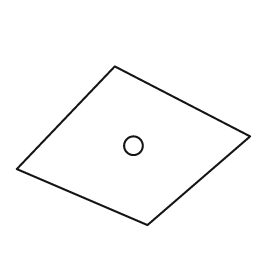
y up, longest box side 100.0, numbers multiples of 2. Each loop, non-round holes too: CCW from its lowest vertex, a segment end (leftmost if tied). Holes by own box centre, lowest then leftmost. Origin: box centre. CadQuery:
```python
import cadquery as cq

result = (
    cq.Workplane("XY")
    .moveTo(6.0, -34.0)
    .lineTo(50.0, 4.0)
    .lineTo(-8.0, 34.0)
    .lineTo(-50.0, -10.0)
    .close()
    .moveTo(0.0, 0.0)
    .circle(4.0)
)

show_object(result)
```